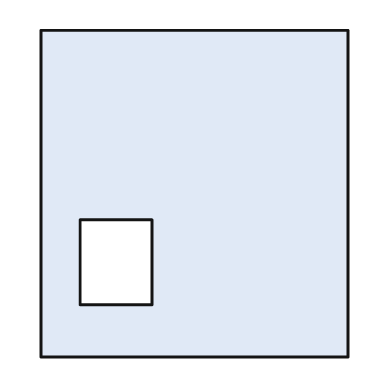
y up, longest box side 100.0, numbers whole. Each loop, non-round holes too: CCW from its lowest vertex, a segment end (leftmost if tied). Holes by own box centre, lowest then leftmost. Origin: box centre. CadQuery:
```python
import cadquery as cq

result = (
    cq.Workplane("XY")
    .moveTo(-47.0, -50.0)
    .lineTo(47.0, -50.0)
    .lineTo(47.0, 50.0)
    .lineTo(-47.0, 50.0)
    .close()
    .moveTo(-35.0, -34.0)
    .lineTo(-13.0, -34.0)
    .lineTo(-13.0, -8.0)
    .lineTo(-35.0, -8.0)
    .close()
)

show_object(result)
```